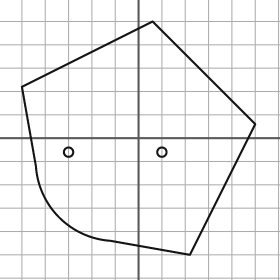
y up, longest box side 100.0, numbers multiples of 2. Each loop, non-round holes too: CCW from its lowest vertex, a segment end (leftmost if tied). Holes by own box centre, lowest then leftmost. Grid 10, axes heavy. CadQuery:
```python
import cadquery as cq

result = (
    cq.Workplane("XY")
    .moveTo(22.0, -50.0)
    .lineTo(50.0, 6.0)
    .lineTo(6.0, 50.0)
    .lineTo(-50.0, 22.0)
    .lineTo(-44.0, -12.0)
    .threePointArc((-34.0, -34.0), (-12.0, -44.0))
    .close()
    .moveTo(-30.0, -6.0)
    .circle(2.0)
    .moveTo(10.0, -6.0)
    .circle(2.0)
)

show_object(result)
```